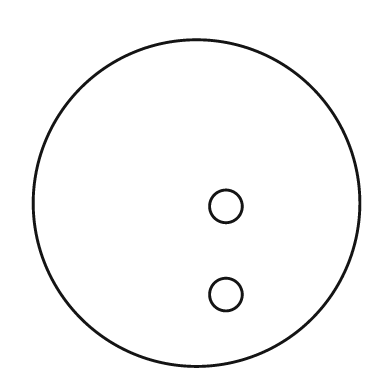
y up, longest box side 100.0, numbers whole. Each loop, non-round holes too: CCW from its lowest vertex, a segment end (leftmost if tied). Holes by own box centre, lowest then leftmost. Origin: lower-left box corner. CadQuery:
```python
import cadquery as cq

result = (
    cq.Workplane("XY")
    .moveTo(50.0, 50.0)
    .circle(50.0)
    .moveTo(59.0, 22.0)
    .circle(5.0)
    .moveTo(59.0, 49.0)
    .circle(5.0)
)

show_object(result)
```